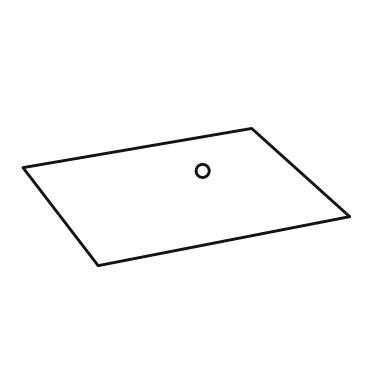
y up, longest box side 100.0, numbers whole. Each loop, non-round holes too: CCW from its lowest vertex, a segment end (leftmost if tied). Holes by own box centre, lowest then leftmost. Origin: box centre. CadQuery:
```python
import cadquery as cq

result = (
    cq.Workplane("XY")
    .moveTo(-27.0, -21.0)
    .lineTo(50.0, -6.0)
    .lineTo(20.0, 21.0)
    .lineTo(-50.0, 9.0)
    .close()
    .moveTo(5.0, 8.0)
    .circle(2.0)
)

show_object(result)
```